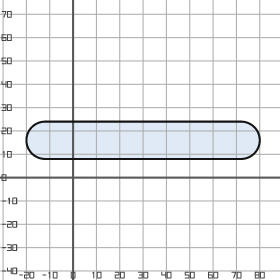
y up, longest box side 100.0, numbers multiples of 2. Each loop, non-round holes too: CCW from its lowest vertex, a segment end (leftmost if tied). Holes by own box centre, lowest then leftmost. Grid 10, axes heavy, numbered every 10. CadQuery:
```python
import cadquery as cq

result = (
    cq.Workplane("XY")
    .moveTo(-12.0, 8.0)
    .lineTo(72.0, 8.0)
    .threePointArc((80.0, 16.0), (72.0, 24.0))
    .lineTo(-12.0, 24.0)
    .threePointArc((-20.0, 16.0), (-12.0, 8.0))
    .close()
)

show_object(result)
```